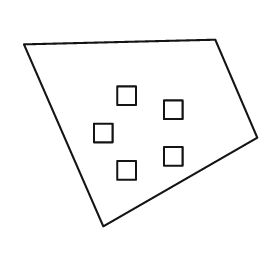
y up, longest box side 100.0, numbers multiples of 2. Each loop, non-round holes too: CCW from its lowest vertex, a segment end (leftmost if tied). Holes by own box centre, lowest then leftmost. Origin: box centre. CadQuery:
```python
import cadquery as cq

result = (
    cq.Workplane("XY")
    .moveTo(-16.0, -40.0)
    .lineTo(50.0, -2.0)
    .lineTo(32.0, 40.0)
    .lineTo(-50.0, 38.0)
    .close()
    .moveTo(-10.0, -20.0)
    .lineTo(-2.0, -20.0)
    .lineTo(-2.0, -12.0)
    .lineTo(-10.0, -12.0)
    .close()
    .moveTo(10.0, -14.0)
    .lineTo(18.0, -14.0)
    .lineTo(18.0, -6.0)
    .lineTo(10.0, -6.0)
    .close()
    .moveTo(-20.0, -4.0)
    .lineTo(-12.0, -4.0)
    .lineTo(-12.0, 4.0)
    .lineTo(-20.0, 4.0)
    .close()
    .moveTo(10.0, 6.0)
    .lineTo(18.0, 6.0)
    .lineTo(18.0, 14.0)
    .lineTo(10.0, 14.0)
    .close()
    .moveTo(-10.0, 12.0)
    .lineTo(-2.0, 12.0)
    .lineTo(-2.0, 20.0)
    .lineTo(-10.0, 20.0)
    .close()
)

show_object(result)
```